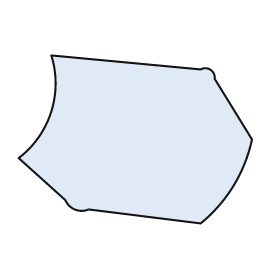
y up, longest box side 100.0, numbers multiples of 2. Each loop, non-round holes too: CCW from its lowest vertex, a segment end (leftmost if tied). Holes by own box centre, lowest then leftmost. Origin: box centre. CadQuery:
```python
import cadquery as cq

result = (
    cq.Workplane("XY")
    .moveTo(28.0, -36.0)
    .threePointArc((42.0, -20.0), (50.0, 0.0))
    .lineTo(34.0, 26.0)
    .threePointArc((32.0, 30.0), (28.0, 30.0))
    .lineTo(-36.0, 36.0)
    .threePointArc((-36.0, 12.0), (-50.0, -8.0))
    .lineTo(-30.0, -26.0)
    .threePointArc((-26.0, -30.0), (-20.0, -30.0))
    .close()
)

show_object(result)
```